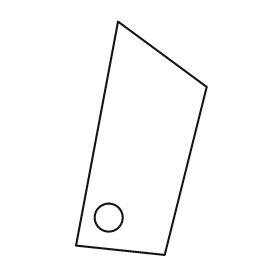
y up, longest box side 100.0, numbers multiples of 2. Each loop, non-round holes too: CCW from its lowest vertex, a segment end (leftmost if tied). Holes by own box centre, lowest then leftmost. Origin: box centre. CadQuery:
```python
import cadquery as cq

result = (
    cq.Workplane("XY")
    .moveTo(10.0, -50.0)
    .lineTo(28.0, 22.0)
    .lineTo(-10.0, 50.0)
    .lineTo(-28.0, -46.0)
    .close()
    .moveTo(-14.0, -34.0)
    .circle(6.0)
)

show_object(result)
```